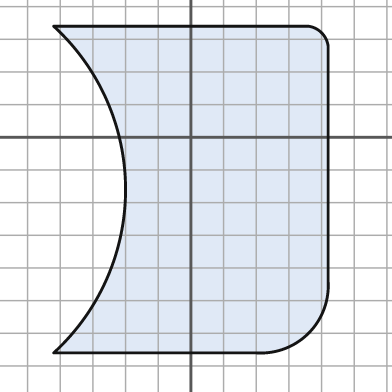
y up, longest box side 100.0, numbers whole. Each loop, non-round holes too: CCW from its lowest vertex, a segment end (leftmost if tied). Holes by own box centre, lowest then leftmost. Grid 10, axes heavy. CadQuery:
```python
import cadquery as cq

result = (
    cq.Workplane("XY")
    .moveTo(-42.0, -66.0)
    .lineTo(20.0, -66.0)
    .threePointArc((36.0, -60.0), (42.0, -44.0))
    .lineTo(42.0, 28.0)
    .threePointArc((40.0, 32.0), (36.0, 34.0))
    .lineTo(-42.0, 34.0)
    .threePointArc((-20.0, -16.0), (-42.0, -66.0))
    .close()
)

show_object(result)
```